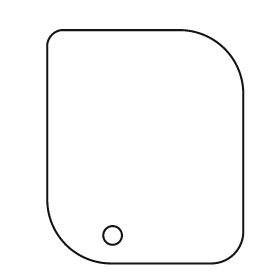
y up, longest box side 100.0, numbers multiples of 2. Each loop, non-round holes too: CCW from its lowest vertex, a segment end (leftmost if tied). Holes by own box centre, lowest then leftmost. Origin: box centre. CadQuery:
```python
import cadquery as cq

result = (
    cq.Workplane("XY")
    .moveTo(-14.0, -50.0)
    .lineTo(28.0, -50.0)
    .threePointArc((38.0, -46.0), (42.0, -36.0))
    .lineTo(42.0, 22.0)
    .threePointArc((34.0, 42.0), (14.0, 50.0))
    .lineTo(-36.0, 50.0)
    .threePointArc((-40.0, 48.0), (-42.0, 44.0))
    .lineTo(-42.0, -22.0)
    .threePointArc((-34.0, -42.0), (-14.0, -50.0))
    .close()
    .moveTo(-14.0, -38.0)
    .circle(4.0)
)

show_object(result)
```